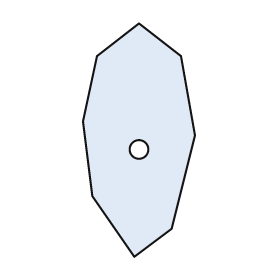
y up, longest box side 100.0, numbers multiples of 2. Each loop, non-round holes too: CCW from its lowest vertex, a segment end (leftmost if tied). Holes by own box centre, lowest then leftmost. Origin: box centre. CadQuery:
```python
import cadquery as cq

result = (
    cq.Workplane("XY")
    .moveTo(-2.0, -50.0)
    .lineTo(14.0, -38.0)
    .lineTo(24.0, 2.0)
    .lineTo(18.0, 36.0)
    .lineTo(0.0, 50.0)
    .lineTo(-18.0, 36.0)
    .lineTo(-24.0, 8.0)
    .lineTo(-20.0, -24.0)
    .close()
    .moveTo(0.0, -4.0)
    .circle(4.0)
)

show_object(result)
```